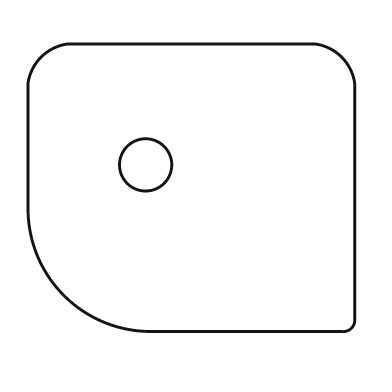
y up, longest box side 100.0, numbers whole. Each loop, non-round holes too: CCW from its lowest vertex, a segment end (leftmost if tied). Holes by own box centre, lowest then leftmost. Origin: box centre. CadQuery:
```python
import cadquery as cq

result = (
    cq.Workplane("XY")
    .moveTo(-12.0, -44.0)
    .lineTo(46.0, -44.0)
    .threePointArc((49.0, -43.0), (50.0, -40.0))
    .lineTo(50.0, 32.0)
    .threePointArc((46.0, 40.0), (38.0, 44.0))
    .lineTo(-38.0, 44.0)
    .threePointArc((-46.0, 40.0), (-50.0, 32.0))
    .lineTo(-50.0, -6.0)
    .threePointArc((-39.0, -33.0), (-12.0, -44.0))
    .close()
    .moveTo(-14.0, 7.0)
    .circle(8.0)
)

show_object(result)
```